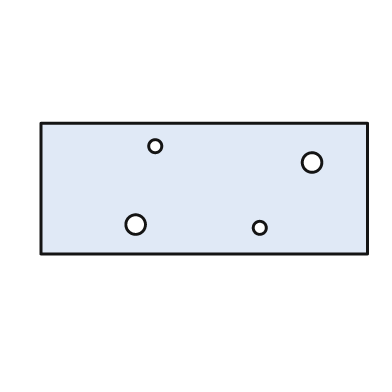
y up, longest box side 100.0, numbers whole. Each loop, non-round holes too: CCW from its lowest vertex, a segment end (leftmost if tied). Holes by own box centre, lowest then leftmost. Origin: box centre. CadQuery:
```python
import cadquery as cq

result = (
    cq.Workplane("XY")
    .moveTo(-50.0, -20.0)
    .lineTo(50.0, -20.0)
    .lineTo(50.0, 20.0)
    .lineTo(-50.0, 20.0)
    .close()
    .moveTo(17.0, -12.0)
    .circle(2.0)
    .moveTo(-21.0, -11.0)
    .circle(3.0)
    .moveTo(33.0, 8.0)
    .circle(3.0)
    .moveTo(-15.0, 13.0)
    .circle(2.0)
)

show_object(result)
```